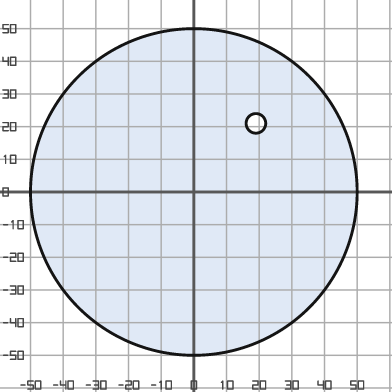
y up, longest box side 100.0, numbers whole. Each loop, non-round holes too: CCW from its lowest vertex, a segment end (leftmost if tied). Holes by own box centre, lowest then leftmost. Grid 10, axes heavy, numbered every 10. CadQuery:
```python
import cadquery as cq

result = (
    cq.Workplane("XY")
    .moveTo(0.0, 0.0)
    .circle(50.0)
    .moveTo(19.0, 21.0)
    .circle(3.0)
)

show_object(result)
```